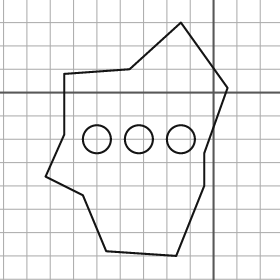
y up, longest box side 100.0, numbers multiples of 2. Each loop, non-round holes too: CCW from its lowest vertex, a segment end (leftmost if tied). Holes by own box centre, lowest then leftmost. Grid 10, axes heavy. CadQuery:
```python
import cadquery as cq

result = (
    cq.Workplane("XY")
    .moveTo(-16.0, -70.0)
    .lineTo(-4.0, -40.0)
    .lineTo(-4.0, -26.0)
    .lineTo(6.0, 2.0)
    .lineTo(-14.0, 30.0)
    .lineTo(-36.0, 10.0)
    .lineTo(-64.0, 8.0)
    .lineTo(-64.0, -18.0)
    .lineTo(-72.0, -36.0)
    .lineTo(-56.0, -44.0)
    .lineTo(-46.0, -68.0)
    .close()
    .moveTo(-50.0, -20.0)
    .circle(6.0)
    .moveTo(-32.0, -20.0)
    .circle(6.0)
    .moveTo(-14.0, -20.0)
    .circle(6.0)
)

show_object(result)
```